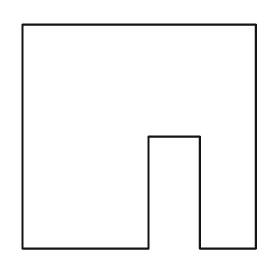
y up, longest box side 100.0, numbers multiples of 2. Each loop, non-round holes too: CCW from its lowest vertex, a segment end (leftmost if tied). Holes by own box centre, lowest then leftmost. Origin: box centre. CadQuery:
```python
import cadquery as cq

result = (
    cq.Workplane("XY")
    .moveTo(-50.0, -48.0)
    .lineTo(4.0, -48.0)
    .lineTo(4.0, 0.0)
    .lineTo(26.0, 0.0)
    .lineTo(26.0, -48.0)
    .lineTo(50.0, -48.0)
    .lineTo(50.0, 48.0)
    .lineTo(-50.0, 48.0)
    .close()
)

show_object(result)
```